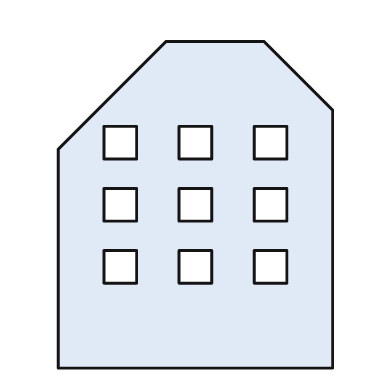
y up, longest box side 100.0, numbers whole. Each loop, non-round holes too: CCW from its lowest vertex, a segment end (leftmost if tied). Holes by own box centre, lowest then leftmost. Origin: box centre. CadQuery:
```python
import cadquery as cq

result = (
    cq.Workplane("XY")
    .moveTo(-42.0, -50.0)
    .lineTo(42.0, -50.0)
    .lineTo(42.0, 29.0)
    .lineTo(21.0, 50.0)
    .lineTo(-9.0, 50.0)
    .lineTo(-42.0, 17.0)
    .close()
    .moveTo(-28.0, -24.0)
    .lineTo(-18.0, -24.0)
    .lineTo(-18.0, -14.0)
    .lineTo(-28.0, -14.0)
    .close()
    .moveTo(-5.0, -24.0)
    .lineTo(5.0, -24.0)
    .lineTo(5.0, -14.0)
    .lineTo(-5.0, -14.0)
    .close()
    .moveTo(18.0, -24.0)
    .lineTo(28.0, -24.0)
    .lineTo(28.0, -14.0)
    .lineTo(18.0, -14.0)
    .close()
    .moveTo(-28.0, -5.0)
    .lineTo(-18.0, -5.0)
    .lineTo(-18.0, 5.0)
    .lineTo(-28.0, 5.0)
    .close()
    .moveTo(-5.0, -5.0)
    .lineTo(5.0, -5.0)
    .lineTo(5.0, 5.0)
    .lineTo(-5.0, 5.0)
    .close()
    .moveTo(18.0, -5.0)
    .lineTo(28.0, -5.0)
    .lineTo(28.0, 5.0)
    .lineTo(18.0, 5.0)
    .close()
    .moveTo(-28.0, 14.0)
    .lineTo(-18.0, 14.0)
    .lineTo(-18.0, 24.0)
    .lineTo(-28.0, 24.0)
    .close()
    .moveTo(-5.0, 14.0)
    .lineTo(5.0, 14.0)
    .lineTo(5.0, 24.0)
    .lineTo(-5.0, 24.0)
    .close()
    .moveTo(18.0, 14.0)
    .lineTo(28.0, 14.0)
    .lineTo(28.0, 24.0)
    .lineTo(18.0, 24.0)
    .close()
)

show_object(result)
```